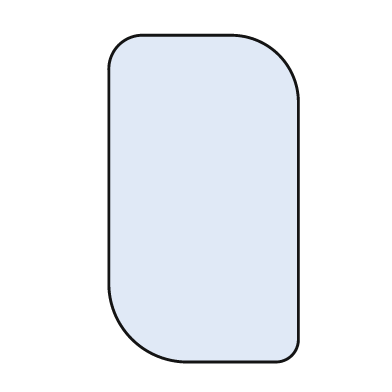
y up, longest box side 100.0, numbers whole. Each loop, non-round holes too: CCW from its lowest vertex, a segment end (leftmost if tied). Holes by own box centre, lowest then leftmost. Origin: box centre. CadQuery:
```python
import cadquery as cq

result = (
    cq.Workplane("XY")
    .moveTo(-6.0, -50.0)
    .lineTo(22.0, -50.0)
    .threePointArc((27.0, -48.0), (29.0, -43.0))
    .lineTo(29.0, 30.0)
    .threePointArc((23.0, 44.0), (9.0, 50.0))
    .lineTo(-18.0, 50.0)
    .threePointArc((-26.0, 47.0), (-29.0, 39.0))
    .lineTo(-29.0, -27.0)
    .threePointArc((-22.0, -43.0), (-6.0, -50.0))
    .close()
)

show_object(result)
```